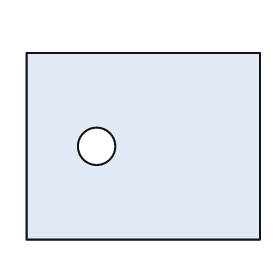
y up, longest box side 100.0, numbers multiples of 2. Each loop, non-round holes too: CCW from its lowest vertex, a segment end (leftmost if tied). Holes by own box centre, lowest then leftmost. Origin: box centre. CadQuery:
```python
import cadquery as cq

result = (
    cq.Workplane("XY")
    .moveTo(-50.0, -40.0)
    .lineTo(50.0, -40.0)
    .lineTo(50.0, 40.0)
    .lineTo(-50.0, 40.0)
    .close()
    .moveTo(-20.0, 0.0)
    .circle(8.0)
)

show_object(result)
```